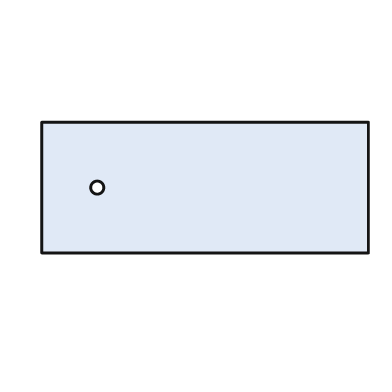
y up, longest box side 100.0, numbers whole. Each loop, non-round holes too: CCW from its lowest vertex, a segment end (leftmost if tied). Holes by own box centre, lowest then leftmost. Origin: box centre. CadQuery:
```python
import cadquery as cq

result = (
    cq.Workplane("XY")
    .moveTo(-50.0, -20.0)
    .lineTo(50.0, -20.0)
    .lineTo(50.0, 20.0)
    .lineTo(-50.0, 20.0)
    .close()
    .moveTo(-33.0, 0.0)
    .circle(2.0)
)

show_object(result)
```